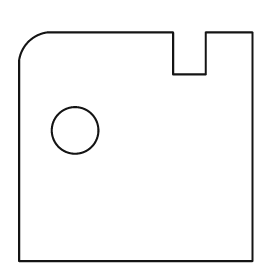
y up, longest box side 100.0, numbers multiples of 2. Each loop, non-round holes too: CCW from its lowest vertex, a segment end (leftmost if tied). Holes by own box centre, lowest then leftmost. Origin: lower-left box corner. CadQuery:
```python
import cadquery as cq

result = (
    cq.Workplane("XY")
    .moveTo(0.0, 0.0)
    .lineTo(100.0, 0.0)
    .lineTo(100.0, 98.0)
    .lineTo(80.0, 98.0)
    .lineTo(80.0, 80.0)
    .lineTo(66.0, 80.0)
    .lineTo(66.0, 98.0)
    .lineTo(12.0, 98.0)
    .threePointArc((4.0, 94.0), (0.0, 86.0))
    .close()
    .moveTo(24.0, 56.0)
    .circle(10.0)
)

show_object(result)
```